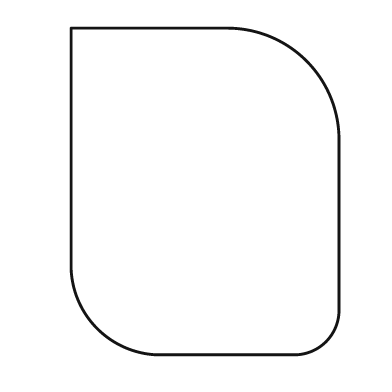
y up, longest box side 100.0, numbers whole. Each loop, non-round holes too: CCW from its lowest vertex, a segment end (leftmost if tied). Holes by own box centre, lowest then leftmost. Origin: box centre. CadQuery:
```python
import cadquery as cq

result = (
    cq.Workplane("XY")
    .moveTo(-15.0, -50.0)
    .lineTo(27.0, -50.0)
    .threePointArc((37.0, -46.0), (41.0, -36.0))
    .lineTo(41.0, 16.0)
    .threePointArc((31.0, 40.0), (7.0, 50.0))
    .lineTo(-41.0, 50.0)
    .lineTo(-41.0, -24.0)
    .threePointArc((-33.0, -42.0), (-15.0, -50.0))
    .close()
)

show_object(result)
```